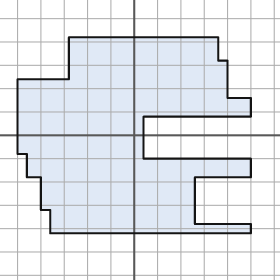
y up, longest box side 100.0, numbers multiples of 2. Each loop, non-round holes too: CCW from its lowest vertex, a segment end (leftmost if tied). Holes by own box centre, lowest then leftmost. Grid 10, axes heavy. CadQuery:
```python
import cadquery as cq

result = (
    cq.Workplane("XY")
    .moveTo(-36.0, -42.0)
    .lineTo(50.0, -42.0)
    .lineTo(50.0, -38.0)
    .lineTo(26.0, -38.0)
    .lineTo(26.0, -18.0)
    .lineTo(50.0, -18.0)
    .lineTo(50.0, -10.0)
    .lineTo(4.0, -10.0)
    .lineTo(4.0, 8.0)
    .lineTo(50.0, 8.0)
    .lineTo(50.0, 16.0)
    .lineTo(40.0, 16.0)
    .lineTo(40.0, 32.0)
    .lineTo(36.0, 32.0)
    .lineTo(36.0, 42.0)
    .lineTo(-28.0, 42.0)
    .lineTo(-28.0, 24.0)
    .lineTo(-50.0, 24.0)
    .lineTo(-50.0, -8.0)
    .lineTo(-46.0, -8.0)
    .lineTo(-46.0, -18.0)
    .lineTo(-40.0, -18.0)
    .lineTo(-40.0, -32.0)
    .lineTo(-36.0, -32.0)
    .close()
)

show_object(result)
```